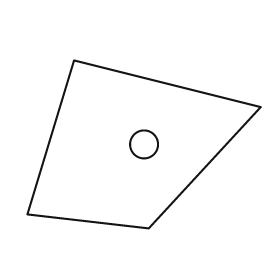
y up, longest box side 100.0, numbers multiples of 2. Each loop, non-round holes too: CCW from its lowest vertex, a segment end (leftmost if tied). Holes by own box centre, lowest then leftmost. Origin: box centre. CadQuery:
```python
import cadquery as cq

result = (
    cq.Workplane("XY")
    .moveTo(2.0, -36.0)
    .lineTo(50.0, 16.0)
    .lineTo(-30.0, 36.0)
    .lineTo(-50.0, -30.0)
    .close()
    .moveTo(0.0, 0.0)
    .circle(6.0)
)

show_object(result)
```